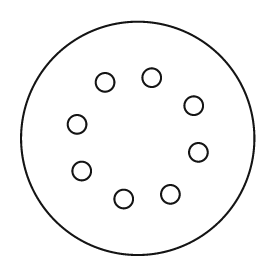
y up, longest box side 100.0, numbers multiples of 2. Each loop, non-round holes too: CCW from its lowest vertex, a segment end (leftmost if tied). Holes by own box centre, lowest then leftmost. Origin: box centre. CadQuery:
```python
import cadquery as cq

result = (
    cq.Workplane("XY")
    .moveTo(0.0, 0.0)
    .circle(50.0)
    .moveTo(-6.0, -26.0)
    .circle(4.0)
    .moveTo(14.0, -24.0)
    .circle(4.0)
    .moveTo(-24.0, -14.0)
    .circle(4.0)
    .moveTo(26.0, -6.0)
    .circle(4.0)
    .moveTo(-26.0, 6.0)
    .circle(4.0)
    .moveTo(24.0, 14.0)
    .circle(4.0)
    .moveTo(-14.0, 24.0)
    .circle(4.0)
    .moveTo(6.0, 26.0)
    .circle(4.0)
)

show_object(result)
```